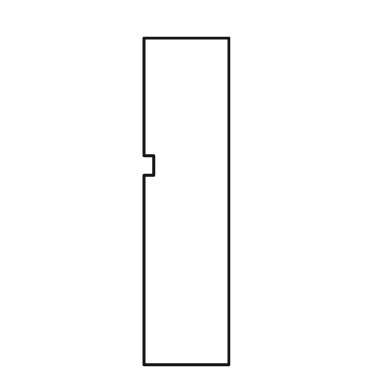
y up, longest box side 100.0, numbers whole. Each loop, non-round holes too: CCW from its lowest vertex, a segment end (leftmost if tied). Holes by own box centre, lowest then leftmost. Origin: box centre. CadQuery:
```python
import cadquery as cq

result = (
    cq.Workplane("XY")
    .moveTo(-13.0, -50.0)
    .lineTo(13.0, -50.0)
    .lineTo(13.0, 50.0)
    .lineTo(-13.0, 50.0)
    .lineTo(-13.0, 14.0)
    .lineTo(-10.0, 14.0)
    .lineTo(-10.0, 8.0)
    .lineTo(-13.0, 8.0)
    .close()
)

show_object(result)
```